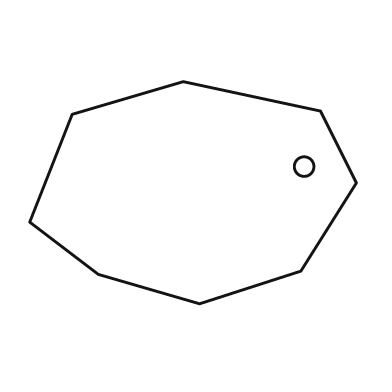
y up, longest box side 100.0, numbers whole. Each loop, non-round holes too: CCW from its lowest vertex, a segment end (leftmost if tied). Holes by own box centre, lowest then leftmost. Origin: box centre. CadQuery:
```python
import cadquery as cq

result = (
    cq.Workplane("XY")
    .moveTo(2.0, -34.0)
    .lineTo(33.0, -24.0)
    .lineTo(50.0, 3.0)
    .lineTo(39.0, 25.0)
    .lineTo(-3.0, 34.0)
    .lineTo(-37.0, 24.0)
    .lineTo(-50.0, -9.0)
    .lineTo(-29.0, -25.0)
    .close()
    .moveTo(34.0, 8.0)
    .circle(3.0)
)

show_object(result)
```